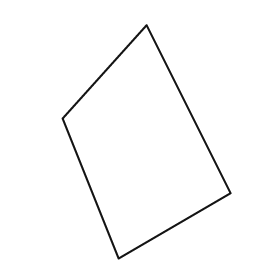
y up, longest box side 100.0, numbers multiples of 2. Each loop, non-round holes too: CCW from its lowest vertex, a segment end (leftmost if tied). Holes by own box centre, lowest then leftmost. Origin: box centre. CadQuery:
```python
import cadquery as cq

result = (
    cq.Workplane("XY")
    .moveTo(-12.0, -50.0)
    .lineTo(36.0, -22.0)
    .lineTo(0.0, 50.0)
    .lineTo(-36.0, 10.0)
    .close()
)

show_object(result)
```